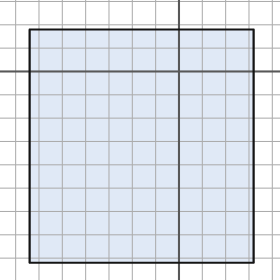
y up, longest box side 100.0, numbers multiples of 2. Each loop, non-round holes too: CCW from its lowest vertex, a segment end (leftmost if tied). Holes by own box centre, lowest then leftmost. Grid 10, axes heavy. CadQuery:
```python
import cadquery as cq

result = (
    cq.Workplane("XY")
    .moveTo(-64.0, -82.0)
    .lineTo(32.0, -82.0)
    .lineTo(32.0, 18.0)
    .lineTo(-64.0, 18.0)
    .close()
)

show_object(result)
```